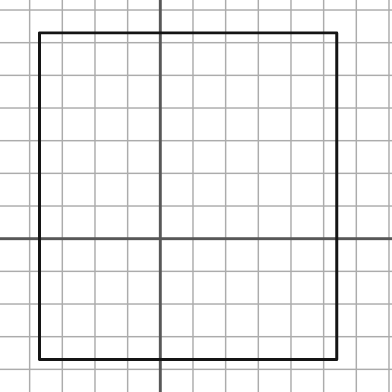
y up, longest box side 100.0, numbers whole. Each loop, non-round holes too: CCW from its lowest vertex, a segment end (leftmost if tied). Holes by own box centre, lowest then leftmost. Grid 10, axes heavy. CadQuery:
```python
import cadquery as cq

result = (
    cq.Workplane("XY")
    .moveTo(-37.0, -37.0)
    .lineTo(54.0, -37.0)
    .lineTo(54.0, 63.0)
    .lineTo(-37.0, 63.0)
    .close()
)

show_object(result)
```